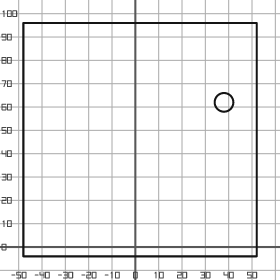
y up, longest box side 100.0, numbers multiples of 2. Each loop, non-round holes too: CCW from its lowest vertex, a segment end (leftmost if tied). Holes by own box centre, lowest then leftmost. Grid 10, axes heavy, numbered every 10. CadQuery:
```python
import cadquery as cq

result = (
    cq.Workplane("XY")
    .moveTo(-48.0, -4.0)
    .lineTo(52.0, -4.0)
    .lineTo(52.0, 96.0)
    .lineTo(-48.0, 96.0)
    .close()
    .moveTo(38.0, 62.0)
    .circle(4.0)
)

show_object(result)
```